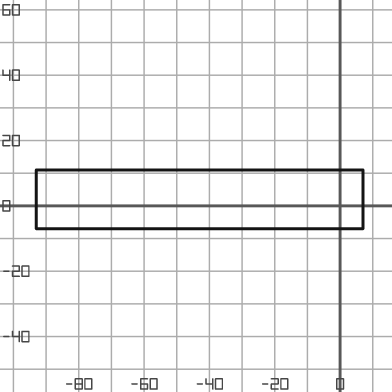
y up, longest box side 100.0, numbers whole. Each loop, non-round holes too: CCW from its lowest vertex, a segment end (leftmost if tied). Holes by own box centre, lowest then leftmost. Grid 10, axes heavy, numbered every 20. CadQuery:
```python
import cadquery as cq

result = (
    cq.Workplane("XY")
    .moveTo(-93.0, -7.0)
    .lineTo(7.0, -7.0)
    .lineTo(7.0, 11.0)
    .lineTo(-93.0, 11.0)
    .close()
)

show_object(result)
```